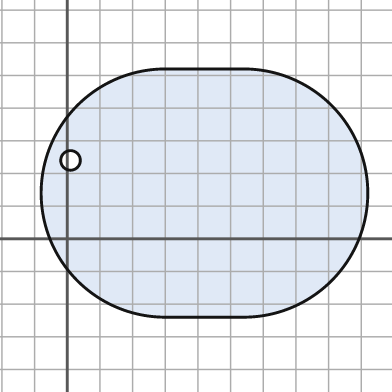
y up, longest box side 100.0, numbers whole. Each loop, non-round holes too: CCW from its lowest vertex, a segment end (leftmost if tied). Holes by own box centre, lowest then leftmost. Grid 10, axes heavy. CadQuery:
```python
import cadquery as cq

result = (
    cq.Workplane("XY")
    .moveTo(30.0, -24.0)
    .lineTo(54.0, -24.0)
    .threePointArc((92.0, 14.0), (54.0, 52.0))
    .lineTo(30.0, 52.0)
    .threePointArc((-8.0, 14.0), (30.0, -24.0))
    .close()
    .moveTo(1.0, 24.0)
    .circle(3.0)
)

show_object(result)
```